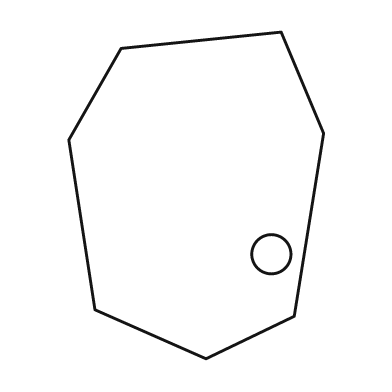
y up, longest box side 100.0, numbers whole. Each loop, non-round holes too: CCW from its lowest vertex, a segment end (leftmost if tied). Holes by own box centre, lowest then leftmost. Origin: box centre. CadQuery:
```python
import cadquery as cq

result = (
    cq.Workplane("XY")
    .moveTo(3.0, -50.0)
    .lineTo(30.0, -37.0)
    .lineTo(39.0, 19.0)
    .lineTo(26.0, 50.0)
    .lineTo(-23.0, 45.0)
    .lineTo(-39.0, 17.0)
    .lineTo(-31.0, -35.0)
    .close()
    .moveTo(23.0, -18.0)
    .circle(6.0)
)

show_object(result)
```